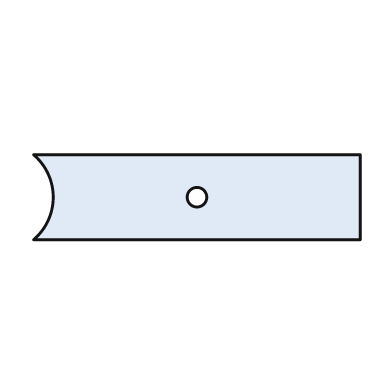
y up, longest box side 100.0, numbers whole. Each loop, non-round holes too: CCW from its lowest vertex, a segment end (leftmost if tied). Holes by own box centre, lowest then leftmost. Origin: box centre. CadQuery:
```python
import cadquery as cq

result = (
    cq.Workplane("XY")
    .moveTo(-50.0, -13.0)
    .lineTo(50.0, -13.0)
    .lineTo(50.0, 13.0)
    .lineTo(-50.0, 13.0)
    .threePointArc((-44.0, 0.0), (-50.0, -13.0))
    .close()
    .moveTo(0.0, 0.0)
    .circle(3.0)
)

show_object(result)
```